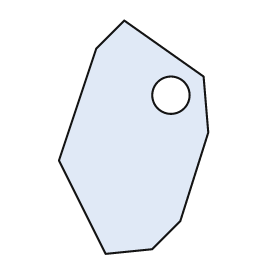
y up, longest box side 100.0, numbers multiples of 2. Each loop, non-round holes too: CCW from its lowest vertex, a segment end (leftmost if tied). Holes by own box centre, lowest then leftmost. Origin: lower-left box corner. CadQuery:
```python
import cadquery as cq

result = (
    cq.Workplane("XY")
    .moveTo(20.0, 0.0)
    .lineTo(40.0, 2.0)
    .lineTo(52.0, 14.0)
    .lineTo(64.0, 52.0)
    .lineTo(62.0, 76.0)
    .lineTo(28.0, 100.0)
    .lineTo(16.0, 88.0)
    .lineTo(0.0, 40.0)
    .close()
    .moveTo(48.0, 68.0)
    .circle(8.0)
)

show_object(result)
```